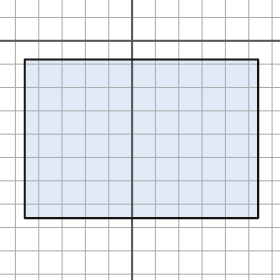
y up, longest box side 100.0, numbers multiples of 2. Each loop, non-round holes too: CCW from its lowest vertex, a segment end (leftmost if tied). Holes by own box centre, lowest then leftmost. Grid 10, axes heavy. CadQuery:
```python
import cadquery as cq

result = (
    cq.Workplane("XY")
    .moveTo(-46.0, -76.0)
    .lineTo(54.0, -76.0)
    .lineTo(54.0, -8.0)
    .lineTo(-46.0, -8.0)
    .close()
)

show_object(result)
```